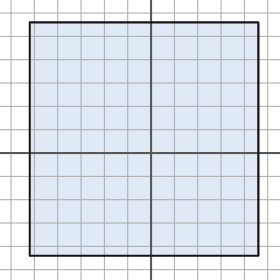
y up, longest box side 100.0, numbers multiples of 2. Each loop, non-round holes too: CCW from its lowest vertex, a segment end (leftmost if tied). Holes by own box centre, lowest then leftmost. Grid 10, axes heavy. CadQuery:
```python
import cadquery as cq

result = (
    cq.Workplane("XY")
    .moveTo(-52.0, -44.0)
    .lineTo(46.0, -44.0)
    .lineTo(46.0, 56.0)
    .lineTo(-52.0, 56.0)
    .close()
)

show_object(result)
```